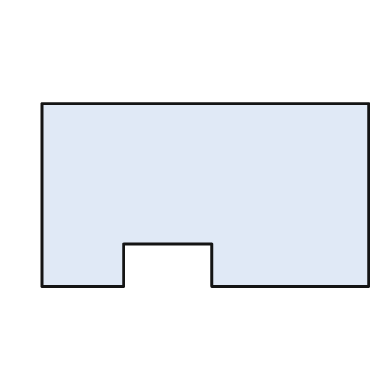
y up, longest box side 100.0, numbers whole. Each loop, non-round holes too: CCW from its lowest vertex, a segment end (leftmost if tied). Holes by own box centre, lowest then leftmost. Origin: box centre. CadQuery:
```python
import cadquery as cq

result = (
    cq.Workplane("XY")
    .moveTo(-50.0, -28.0)
    .lineTo(-25.0, -28.0)
    .lineTo(-25.0, -15.0)
    .lineTo(2.0, -15.0)
    .lineTo(2.0, -28.0)
    .lineTo(50.0, -28.0)
    .lineTo(50.0, 28.0)
    .lineTo(-50.0, 28.0)
    .close()
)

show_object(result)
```